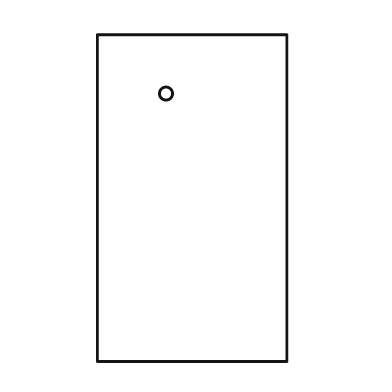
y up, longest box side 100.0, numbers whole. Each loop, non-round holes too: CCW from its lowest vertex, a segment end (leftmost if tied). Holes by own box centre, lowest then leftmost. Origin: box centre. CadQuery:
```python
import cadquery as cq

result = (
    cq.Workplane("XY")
    .moveTo(-29.0, -50.0)
    .lineTo(29.0, -50.0)
    .lineTo(29.0, 50.0)
    .lineTo(-29.0, 50.0)
    .close()
    .moveTo(-8.0, 32.0)
    .circle(2.0)
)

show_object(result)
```